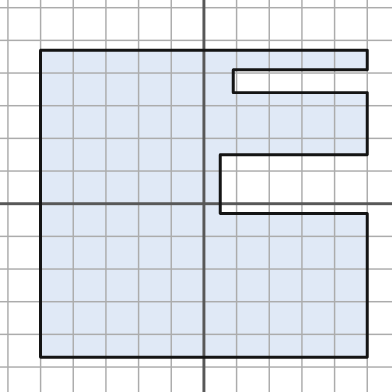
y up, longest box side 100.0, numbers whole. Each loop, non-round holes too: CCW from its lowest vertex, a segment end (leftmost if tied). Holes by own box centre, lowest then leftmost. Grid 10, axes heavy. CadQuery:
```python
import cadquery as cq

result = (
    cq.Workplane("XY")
    .moveTo(-50.0, -47.0)
    .lineTo(50.0, -47.0)
    .lineTo(50.0, -3.0)
    .lineTo(5.0, -3.0)
    .lineTo(5.0, 15.0)
    .lineTo(50.0, 15.0)
    .lineTo(50.0, 34.0)
    .lineTo(9.0, 34.0)
    .lineTo(9.0, 41.0)
    .lineTo(50.0, 41.0)
    .lineTo(50.0, 47.0)
    .lineTo(-50.0, 47.0)
    .close()
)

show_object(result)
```